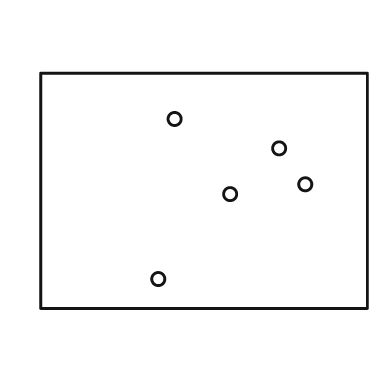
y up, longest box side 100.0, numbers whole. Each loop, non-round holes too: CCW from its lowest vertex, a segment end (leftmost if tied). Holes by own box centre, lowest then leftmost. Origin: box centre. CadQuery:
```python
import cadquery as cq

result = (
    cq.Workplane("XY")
    .moveTo(-50.0, -36.0)
    .lineTo(50.0, -36.0)
    .lineTo(50.0, 36.0)
    .lineTo(-50.0, 36.0)
    .close()
    .moveTo(-14.0, -27.0)
    .circle(2.0)
    .moveTo(8.0, -1.0)
    .circle(2.0)
    .moveTo(31.0, 2.0)
    .circle(2.0)
    .moveTo(23.0, 13.0)
    .circle(2.0)
    .moveTo(-9.0, 22.0)
    .circle(2.0)
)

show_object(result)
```